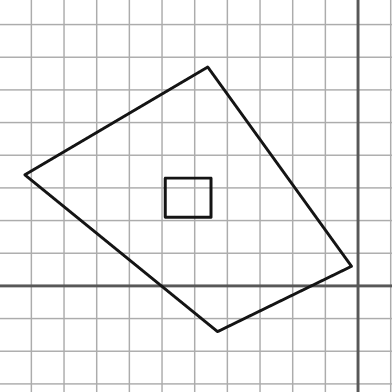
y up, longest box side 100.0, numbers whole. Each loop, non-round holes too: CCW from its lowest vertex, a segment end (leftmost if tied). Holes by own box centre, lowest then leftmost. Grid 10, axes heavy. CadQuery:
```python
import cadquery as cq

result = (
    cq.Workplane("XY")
    .moveTo(-43.0, -14.0)
    .lineTo(-2.0, 6.0)
    .lineTo(-46.0, 67.0)
    .lineTo(-102.0, 34.0)
    .close()
    .moveTo(-59.0, 21.0)
    .lineTo(-45.0, 21.0)
    .lineTo(-45.0, 33.0)
    .lineTo(-59.0, 33.0)
    .close()
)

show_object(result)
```